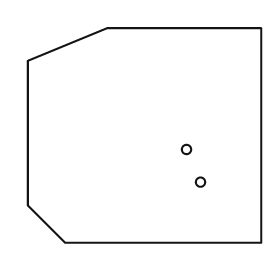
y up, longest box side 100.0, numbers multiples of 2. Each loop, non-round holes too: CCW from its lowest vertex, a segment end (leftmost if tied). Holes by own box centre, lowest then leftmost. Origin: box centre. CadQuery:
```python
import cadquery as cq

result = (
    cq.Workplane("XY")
    .moveTo(-34.0, -46.0)
    .lineTo(50.0, -46.0)
    .lineTo(50.0, 46.0)
    .lineTo(-16.0, 46.0)
    .lineTo(-50.0, 32.0)
    .lineTo(-50.0, -30.0)
    .close()
    .moveTo(24.0, -20.0)
    .circle(2.0)
    .moveTo(18.0, -6.0)
    .circle(2.0)
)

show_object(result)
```